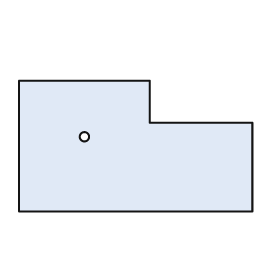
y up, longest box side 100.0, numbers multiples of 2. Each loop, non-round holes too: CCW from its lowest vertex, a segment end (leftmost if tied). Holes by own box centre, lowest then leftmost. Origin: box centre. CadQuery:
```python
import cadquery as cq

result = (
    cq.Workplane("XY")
    .moveTo(-50.0, -28.0)
    .lineTo(50.0, -28.0)
    .lineTo(50.0, 10.0)
    .lineTo(6.0, 10.0)
    .lineTo(6.0, 28.0)
    .lineTo(-50.0, 28.0)
    .close()
    .moveTo(-22.0, 4.0)
    .circle(2.0)
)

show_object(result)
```